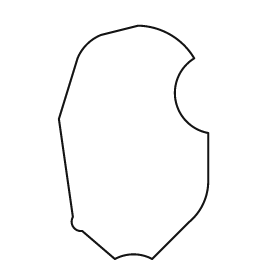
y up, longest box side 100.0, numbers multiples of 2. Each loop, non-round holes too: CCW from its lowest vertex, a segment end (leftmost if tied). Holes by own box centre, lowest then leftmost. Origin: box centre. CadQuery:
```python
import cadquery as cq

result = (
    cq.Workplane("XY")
    .moveTo(-8.0, -50.0)
    .threePointArc((0.0, -48.0), (8.0, -50.0))
    .lineTo(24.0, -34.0)
    .threePointArc((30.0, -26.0), (32.0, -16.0))
    .lineTo(32.0, 4.0)
    .threePointArc((18.0, 18.0), (26.0, 36.0))
    .threePointArc((16.0, 46.0), (2.0, 50.0))
    .lineTo(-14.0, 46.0)
    .threePointArc((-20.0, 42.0), (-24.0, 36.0))
    .lineTo(-32.0, 10.0)
    .lineTo(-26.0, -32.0)
    .threePointArc((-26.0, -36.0), (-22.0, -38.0))
    .close()
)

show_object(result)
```